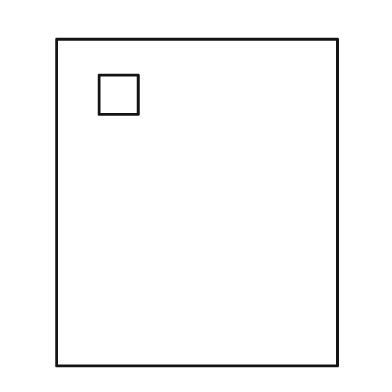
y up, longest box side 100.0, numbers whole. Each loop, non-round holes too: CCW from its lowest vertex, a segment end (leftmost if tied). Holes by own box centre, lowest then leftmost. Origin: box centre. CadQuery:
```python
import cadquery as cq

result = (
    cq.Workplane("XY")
    .moveTo(-43.0, -50.0)
    .lineTo(43.0, -50.0)
    .lineTo(43.0, 50.0)
    .lineTo(-43.0, 50.0)
    .close()
    .moveTo(-30.0, 27.0)
    .lineTo(-18.0, 27.0)
    .lineTo(-18.0, 39.0)
    .lineTo(-30.0, 39.0)
    .close()
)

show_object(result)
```